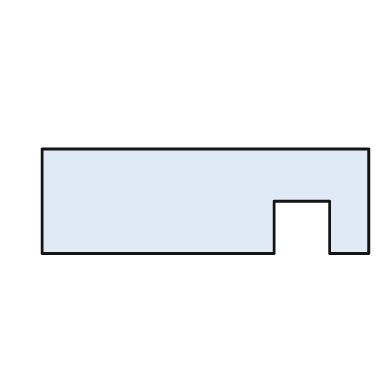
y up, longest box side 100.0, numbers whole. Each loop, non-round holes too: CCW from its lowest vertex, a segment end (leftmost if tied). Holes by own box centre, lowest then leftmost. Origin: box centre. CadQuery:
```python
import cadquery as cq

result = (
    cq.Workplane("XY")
    .moveTo(-50.0, -16.0)
    .lineTo(21.0, -16.0)
    .lineTo(21.0, 0.0)
    .lineTo(38.0, 0.0)
    .lineTo(38.0, -16.0)
    .lineTo(50.0, -16.0)
    .lineTo(50.0, 16.0)
    .lineTo(-50.0, 16.0)
    .close()
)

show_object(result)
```